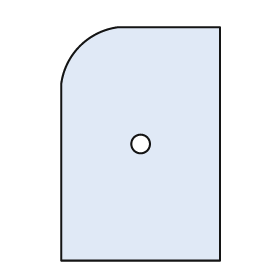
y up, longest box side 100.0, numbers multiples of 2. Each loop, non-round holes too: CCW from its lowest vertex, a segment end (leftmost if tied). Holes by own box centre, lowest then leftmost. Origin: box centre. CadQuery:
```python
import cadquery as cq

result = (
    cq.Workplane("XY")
    .moveTo(-34.0, -50.0)
    .lineTo(34.0, -50.0)
    .lineTo(34.0, 50.0)
    .lineTo(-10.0, 50.0)
    .threePointArc((-26.0, 42.0), (-34.0, 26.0))
    .close()
    .moveTo(0.0, 0.0)
    .circle(4.0)
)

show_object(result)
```